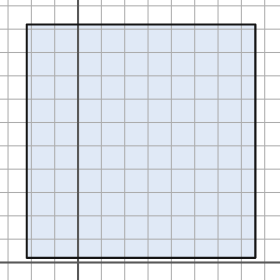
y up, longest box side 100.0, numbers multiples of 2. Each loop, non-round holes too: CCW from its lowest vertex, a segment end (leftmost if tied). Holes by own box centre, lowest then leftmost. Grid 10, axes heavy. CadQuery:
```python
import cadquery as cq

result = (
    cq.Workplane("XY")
    .moveTo(-22.0, 2.0)
    .lineTo(76.0, 2.0)
    .lineTo(76.0, 102.0)
    .lineTo(-22.0, 102.0)
    .close()
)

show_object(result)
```